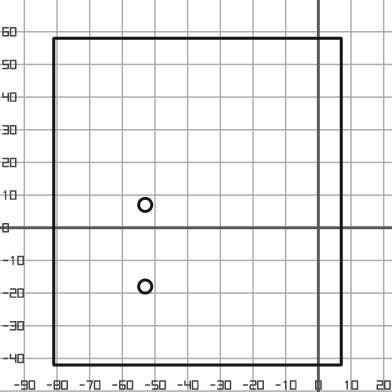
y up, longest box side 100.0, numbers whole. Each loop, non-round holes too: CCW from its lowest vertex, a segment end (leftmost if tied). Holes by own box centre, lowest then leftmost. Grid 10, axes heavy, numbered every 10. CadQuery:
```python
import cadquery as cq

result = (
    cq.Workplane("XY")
    .moveTo(-81.0, -42.0)
    .lineTo(7.0, -42.0)
    .lineTo(7.0, 58.0)
    .lineTo(-81.0, 58.0)
    .close()
    .moveTo(-53.0, -18.0)
    .circle(2.0)
    .moveTo(-53.0, 7.0)
    .circle(2.0)
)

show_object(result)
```